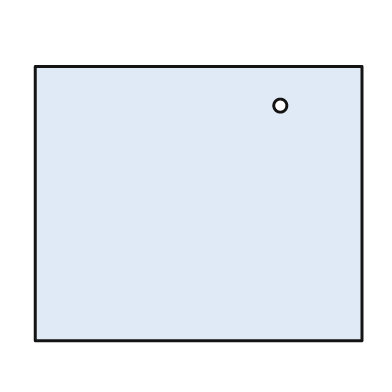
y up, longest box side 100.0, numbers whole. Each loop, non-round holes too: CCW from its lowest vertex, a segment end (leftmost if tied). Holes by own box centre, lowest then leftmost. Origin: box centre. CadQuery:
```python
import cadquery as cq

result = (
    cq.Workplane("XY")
    .moveTo(-50.0, -42.0)
    .lineTo(50.0, -42.0)
    .lineTo(50.0, 42.0)
    .lineTo(-50.0, 42.0)
    .close()
    .moveTo(25.0, 30.0)
    .circle(2.0)
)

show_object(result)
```